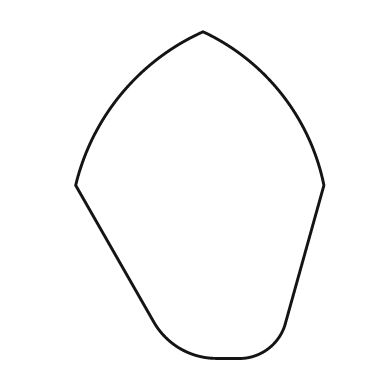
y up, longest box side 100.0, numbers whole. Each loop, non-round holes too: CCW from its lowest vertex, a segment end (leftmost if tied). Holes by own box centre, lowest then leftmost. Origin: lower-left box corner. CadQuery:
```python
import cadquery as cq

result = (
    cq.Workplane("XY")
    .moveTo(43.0, 0.0)
    .lineTo(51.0, 0.0)
    .threePointArc((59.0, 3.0), (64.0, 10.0))
    .lineTo(76.0, 53.0)
    .threePointArc((63.0, 81.0), (39.0, 100.0))
    .threePointArc((14.0, 81.0), (0.0, 53.0))
    .lineTo(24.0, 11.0)
    .threePointArc((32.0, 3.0), (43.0, 0.0))
    .close()
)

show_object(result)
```